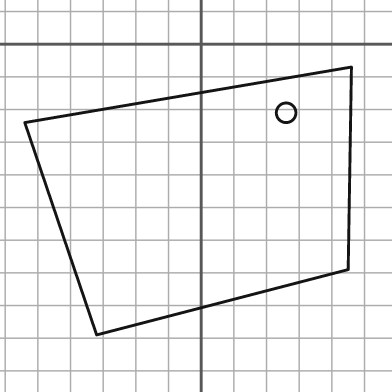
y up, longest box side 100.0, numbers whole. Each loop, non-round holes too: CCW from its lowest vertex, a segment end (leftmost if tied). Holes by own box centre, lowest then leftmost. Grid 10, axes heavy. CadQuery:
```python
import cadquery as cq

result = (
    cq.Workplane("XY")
    .moveTo(-32.0, -89.0)
    .lineTo(45.0, -69.0)
    .lineTo(46.0, -7.0)
    .lineTo(-54.0, -24.0)
    .close()
    .moveTo(26.0, -21.0)
    .circle(3.0)
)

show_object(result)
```